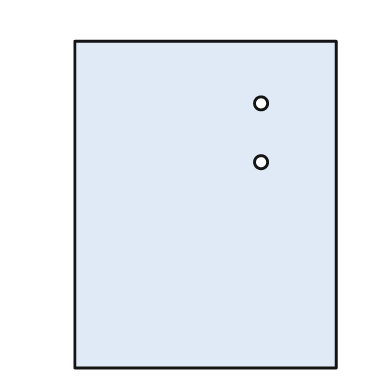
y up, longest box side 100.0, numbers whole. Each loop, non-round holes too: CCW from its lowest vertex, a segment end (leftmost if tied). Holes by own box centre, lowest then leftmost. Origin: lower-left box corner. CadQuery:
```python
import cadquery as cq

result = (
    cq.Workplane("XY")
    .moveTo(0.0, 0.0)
    .lineTo(80.0, 0.0)
    .lineTo(80.0, 100.0)
    .lineTo(0.0, 100.0)
    .close()
    .moveTo(57.0, 63.0)
    .circle(2.0)
    .moveTo(57.0, 81.0)
    .circle(2.0)
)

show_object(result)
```